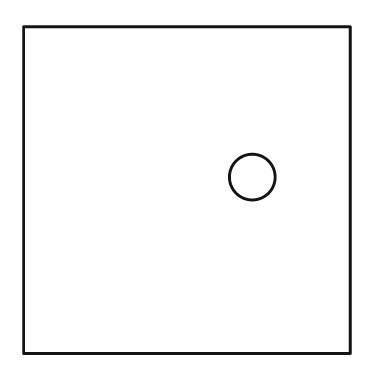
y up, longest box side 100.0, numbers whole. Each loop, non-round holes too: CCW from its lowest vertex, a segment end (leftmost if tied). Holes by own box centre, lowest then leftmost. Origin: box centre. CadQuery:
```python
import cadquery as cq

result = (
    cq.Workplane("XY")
    .moveTo(-50.0, -50.0)
    .lineTo(50.0, -50.0)
    .lineTo(50.0, 50.0)
    .lineTo(-50.0, 50.0)
    .close()
    .moveTo(20.0, 4.0)
    .circle(7.0)
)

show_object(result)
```